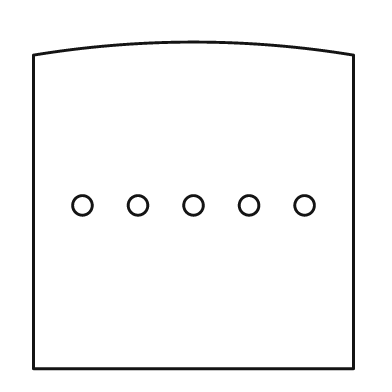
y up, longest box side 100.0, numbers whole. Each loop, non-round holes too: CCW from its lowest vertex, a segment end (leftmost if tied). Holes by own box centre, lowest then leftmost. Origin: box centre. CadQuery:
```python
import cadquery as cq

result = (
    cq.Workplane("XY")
    .moveTo(-49.0, -50.0)
    .lineTo(49.0, -50.0)
    .lineTo(49.0, 46.0)
    .threePointArc((0.0, 50.0), (-49.0, 46.0))
    .close()
    .moveTo(-34.0, 0.0)
    .circle(3.0)
    .moveTo(-17.0, 0.0)
    .circle(3.0)
    .moveTo(0.0, 0.0)
    .circle(3.0)
    .moveTo(17.0, 0.0)
    .circle(3.0)
    .moveTo(34.0, 0.0)
    .circle(3.0)
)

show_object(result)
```